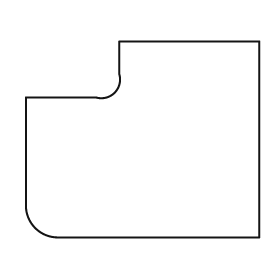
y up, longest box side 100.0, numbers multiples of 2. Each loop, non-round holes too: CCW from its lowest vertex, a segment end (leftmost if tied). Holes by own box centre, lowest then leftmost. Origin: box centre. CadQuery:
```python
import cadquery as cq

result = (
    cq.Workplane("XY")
    .moveTo(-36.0, -42.0)
    .lineTo(50.0, -42.0)
    .lineTo(50.0, 42.0)
    .lineTo(-10.0, 42.0)
    .lineTo(-10.0, 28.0)
    .threePointArc((-12.0, 20.0), (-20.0, 18.0))
    .lineTo(-50.0, 18.0)
    .lineTo(-50.0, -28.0)
    .threePointArc((-46.0, -38.0), (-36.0, -42.0))
    .close()
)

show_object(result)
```